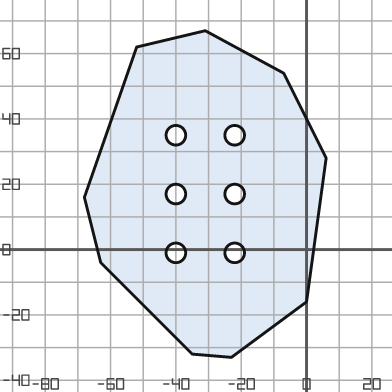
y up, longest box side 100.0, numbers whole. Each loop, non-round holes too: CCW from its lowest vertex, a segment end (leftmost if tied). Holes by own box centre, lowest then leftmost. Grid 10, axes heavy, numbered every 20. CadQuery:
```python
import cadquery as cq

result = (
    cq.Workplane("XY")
    .moveTo(-23.0, -33.0)
    .lineTo(0.0, -16.0)
    .lineTo(6.0, 28.0)
    .lineTo(-7.0, 54.0)
    .lineTo(-31.0, 67.0)
    .lineTo(-52.0, 62.0)
    .lineTo(-68.0, 16.0)
    .lineTo(-63.0, -4.0)
    .lineTo(-35.0, -32.0)
    .close()
    .moveTo(-40.0, -1.0)
    .circle(3.0)
    .moveTo(-22.0, -1.0)
    .circle(3.0)
    .moveTo(-40.0, 17.0)
    .circle(3.0)
    .moveTo(-22.0, 17.0)
    .circle(3.0)
    .moveTo(-40.0, 35.0)
    .circle(3.0)
    .moveTo(-22.0, 35.0)
    .circle(3.0)
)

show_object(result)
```